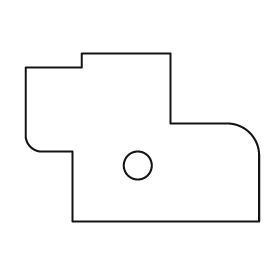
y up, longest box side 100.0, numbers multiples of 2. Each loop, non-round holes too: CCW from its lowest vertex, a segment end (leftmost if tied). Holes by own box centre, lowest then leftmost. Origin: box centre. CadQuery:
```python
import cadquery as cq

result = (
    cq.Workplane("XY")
    .moveTo(-30.0, -36.0)
    .lineTo(50.0, -36.0)
    .lineTo(50.0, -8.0)
    .threePointArc((46.0, 2.0), (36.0, 6.0))
    .lineTo(12.0, 6.0)
    .lineTo(12.0, 36.0)
    .lineTo(-26.0, 36.0)
    .lineTo(-26.0, 30.0)
    .lineTo(-50.0, 30.0)
    .lineTo(-50.0, 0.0)
    .threePointArc((-48.0, -4.0), (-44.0, -6.0))
    .lineTo(-30.0, -6.0)
    .close()
    .moveTo(-2.0, -12.0)
    .circle(6.0)
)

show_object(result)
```